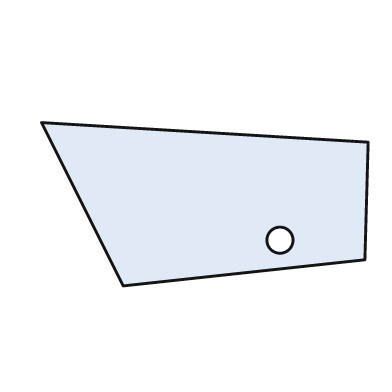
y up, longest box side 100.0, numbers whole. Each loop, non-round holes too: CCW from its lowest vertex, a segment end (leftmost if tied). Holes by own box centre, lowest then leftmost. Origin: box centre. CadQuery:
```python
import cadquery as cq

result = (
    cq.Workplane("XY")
    .moveTo(-25.0, -25.0)
    .lineTo(49.0, -17.0)
    .lineTo(50.0, 19.0)
    .lineTo(-50.0, 25.0)
    .close()
    .moveTo(23.0, -11.0)
    .circle(4.0)
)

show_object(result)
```